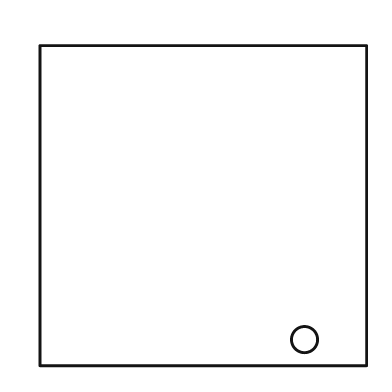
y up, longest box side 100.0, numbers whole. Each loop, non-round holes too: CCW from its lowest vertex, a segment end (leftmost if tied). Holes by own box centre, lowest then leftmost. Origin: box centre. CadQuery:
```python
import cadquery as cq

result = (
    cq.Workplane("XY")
    .moveTo(-50.0, -49.0)
    .lineTo(50.0, -49.0)
    .lineTo(50.0, 49.0)
    .lineTo(-50.0, 49.0)
    .close()
    .moveTo(31.0, -41.0)
    .circle(4.0)
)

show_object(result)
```